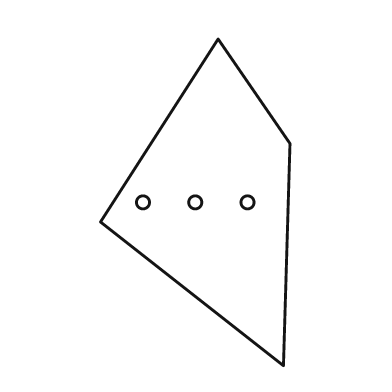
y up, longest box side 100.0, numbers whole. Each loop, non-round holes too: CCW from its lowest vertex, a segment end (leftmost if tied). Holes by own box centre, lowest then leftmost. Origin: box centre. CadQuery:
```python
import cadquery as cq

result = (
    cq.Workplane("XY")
    .moveTo(27.0, -50.0)
    .lineTo(29.0, 18.0)
    .lineTo(7.0, 50.0)
    .lineTo(-29.0, -6.0)
    .close()
    .moveTo(-16.0, 0.0)
    .circle(2.0)
    .moveTo(0.0, 0.0)
    .circle(2.0)
    .moveTo(16.0, 0.0)
    .circle(2.0)
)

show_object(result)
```